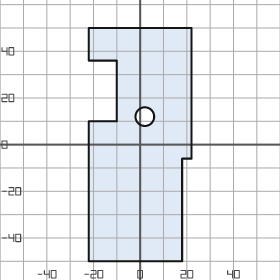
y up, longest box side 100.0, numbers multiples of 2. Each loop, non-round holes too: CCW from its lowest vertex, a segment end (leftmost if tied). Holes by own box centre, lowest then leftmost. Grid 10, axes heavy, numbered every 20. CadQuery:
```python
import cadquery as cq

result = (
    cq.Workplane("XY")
    .moveTo(-22.0, -50.0)
    .lineTo(18.0, -50.0)
    .lineTo(18.0, -6.0)
    .lineTo(22.0, -6.0)
    .lineTo(22.0, 50.0)
    .lineTo(-22.0, 50.0)
    .lineTo(-22.0, 36.0)
    .lineTo(-10.0, 36.0)
    .lineTo(-10.0, 10.0)
    .lineTo(-22.0, 10.0)
    .close()
    .moveTo(2.0, 12.0)
    .circle(4.0)
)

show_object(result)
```